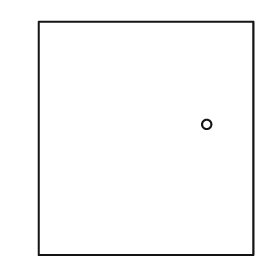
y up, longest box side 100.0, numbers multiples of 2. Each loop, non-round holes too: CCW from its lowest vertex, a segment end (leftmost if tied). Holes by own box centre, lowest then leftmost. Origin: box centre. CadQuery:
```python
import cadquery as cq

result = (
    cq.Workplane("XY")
    .moveTo(-46.0, -50.0)
    .lineTo(46.0, -50.0)
    .lineTo(46.0, 50.0)
    .lineTo(-46.0, 50.0)
    .close()
    .moveTo(26.0, 6.0)
    .circle(2.0)
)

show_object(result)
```